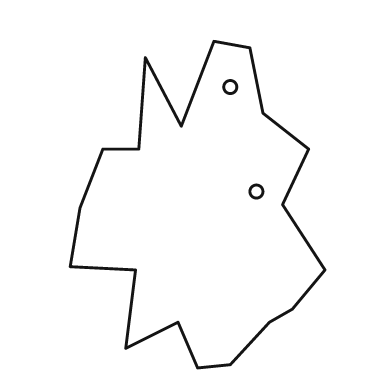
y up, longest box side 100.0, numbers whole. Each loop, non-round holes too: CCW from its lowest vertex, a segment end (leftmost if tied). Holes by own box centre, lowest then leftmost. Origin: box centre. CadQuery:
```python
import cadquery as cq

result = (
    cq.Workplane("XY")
    .moveTo(0.0, -50.0)
    .lineTo(10.0, -49.0)
    .lineTo(22.0, -36.0)
    .lineTo(29.0, -32.0)
    .lineTo(39.0, -20.0)
    .lineTo(26.0, 0.0)
    .lineTo(34.0, 17.0)
    .lineTo(20.0, 28.0)
    .lineTo(16.0, 48.0)
    .lineTo(5.0, 50.0)
    .lineTo(-5.0, 24.0)
    .lineTo(-16.0, 45.0)
    .lineTo(-18.0, 17.0)
    .lineTo(-29.0, 17.0)
    .lineTo(-36.0, -1.0)
    .lineTo(-39.0, -19.0)
    .lineTo(-19.0, -20.0)
    .lineTo(-22.0, -44.0)
    .lineTo(-6.0, -36.0)
    .close()
    .moveTo(18.0, 4.0)
    .circle(2.0)
    .moveTo(10.0, 36.0)
    .circle(2.0)
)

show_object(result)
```